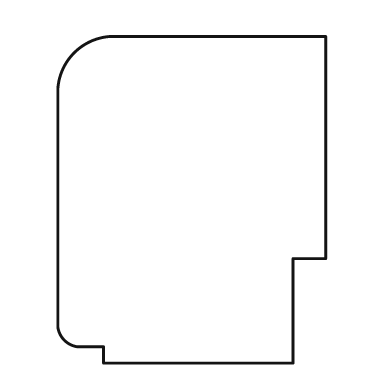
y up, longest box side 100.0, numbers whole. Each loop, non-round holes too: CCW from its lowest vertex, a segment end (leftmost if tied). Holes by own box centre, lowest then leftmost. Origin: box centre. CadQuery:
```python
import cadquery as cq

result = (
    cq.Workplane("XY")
    .moveTo(-27.0, -50.0)
    .lineTo(31.0, -50.0)
    .lineTo(31.0, -18.0)
    .lineTo(41.0, -18.0)
    .lineTo(41.0, 50.0)
    .lineTo(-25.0, 50.0)
    .threePointArc((-36.0, 45.0), (-41.0, 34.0))
    .lineTo(-41.0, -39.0)
    .threePointArc((-39.0, -43.0), (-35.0, -45.0))
    .lineTo(-27.0, -45.0)
    .close()
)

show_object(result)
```